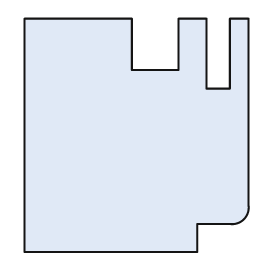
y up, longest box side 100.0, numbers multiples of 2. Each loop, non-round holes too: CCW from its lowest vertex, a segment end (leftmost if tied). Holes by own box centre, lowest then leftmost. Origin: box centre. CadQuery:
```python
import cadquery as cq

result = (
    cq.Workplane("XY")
    .moveTo(-48.0, -50.0)
    .lineTo(26.0, -50.0)
    .lineTo(26.0, -38.0)
    .lineTo(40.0, -38.0)
    .threePointArc((46.0, -36.0), (48.0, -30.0))
    .lineTo(48.0, 50.0)
    .lineTo(40.0, 50.0)
    .lineTo(40.0, 20.0)
    .lineTo(30.0, 20.0)
    .lineTo(30.0, 50.0)
    .lineTo(18.0, 50.0)
    .lineTo(18.0, 28.0)
    .lineTo(-2.0, 28.0)
    .lineTo(-2.0, 50.0)
    .lineTo(-48.0, 50.0)
    .close()
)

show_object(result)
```